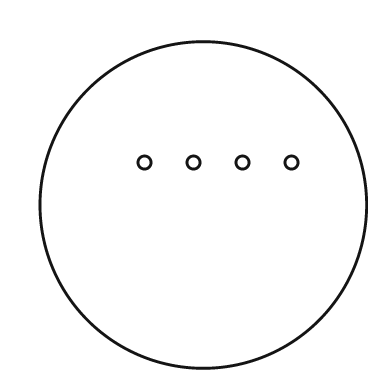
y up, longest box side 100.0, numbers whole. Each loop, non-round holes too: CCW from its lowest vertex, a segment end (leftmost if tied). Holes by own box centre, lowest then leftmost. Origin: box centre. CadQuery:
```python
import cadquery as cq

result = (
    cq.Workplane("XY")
    .moveTo(0.0, 0.0)
    .circle(50.0)
    .moveTo(-18.0, 13.0)
    .circle(2.0)
    .moveTo(-3.0, 13.0)
    .circle(2.0)
    .moveTo(12.0, 13.0)
    .circle(2.0)
    .moveTo(27.0, 13.0)
    .circle(2.0)
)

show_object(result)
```